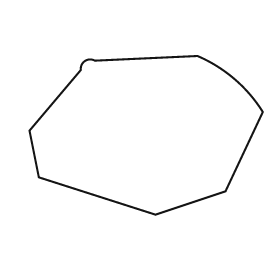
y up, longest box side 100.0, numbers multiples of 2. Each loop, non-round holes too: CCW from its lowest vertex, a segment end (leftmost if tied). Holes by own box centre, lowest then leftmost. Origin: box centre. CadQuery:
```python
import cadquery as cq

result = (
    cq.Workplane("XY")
    .moveTo(4.0, -34.0)
    .lineTo(34.0, -24.0)
    .lineTo(50.0, 10.0)
    .threePointArc((38.0, 24.0), (22.0, 34.0))
    .lineTo(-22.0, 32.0)
    .threePointArc((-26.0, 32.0), (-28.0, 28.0))
    .lineTo(-50.0, 2.0)
    .lineTo(-46.0, -18.0)
    .close()
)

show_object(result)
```